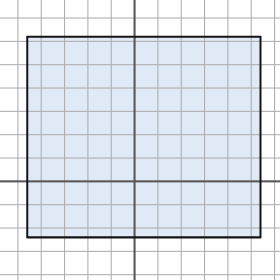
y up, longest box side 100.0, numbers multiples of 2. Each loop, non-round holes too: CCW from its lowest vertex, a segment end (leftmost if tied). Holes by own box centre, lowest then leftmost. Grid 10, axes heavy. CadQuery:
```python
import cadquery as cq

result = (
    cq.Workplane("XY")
    .moveTo(-46.0, -24.0)
    .lineTo(54.0, -24.0)
    .lineTo(54.0, 62.0)
    .lineTo(-46.0, 62.0)
    .close()
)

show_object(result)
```